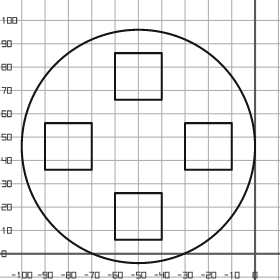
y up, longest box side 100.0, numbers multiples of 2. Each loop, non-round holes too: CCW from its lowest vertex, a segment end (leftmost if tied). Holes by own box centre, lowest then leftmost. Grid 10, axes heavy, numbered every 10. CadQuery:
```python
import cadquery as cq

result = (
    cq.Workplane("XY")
    .moveTo(-50.0, 46.0)
    .circle(50.0)
    .moveTo(-60.0, 6.0)
    .lineTo(-40.0, 6.0)
    .lineTo(-40.0, 26.0)
    .lineTo(-60.0, 26.0)
    .close()
    .moveTo(-90.0, 36.0)
    .lineTo(-70.0, 36.0)
    .lineTo(-70.0, 56.0)
    .lineTo(-90.0, 56.0)
    .close()
    .moveTo(-30.0, 36.0)
    .lineTo(-10.0, 36.0)
    .lineTo(-10.0, 56.0)
    .lineTo(-30.0, 56.0)
    .close()
    .moveTo(-60.0, 66.0)
    .lineTo(-40.0, 66.0)
    .lineTo(-40.0, 86.0)
    .lineTo(-60.0, 86.0)
    .close()
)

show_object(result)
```